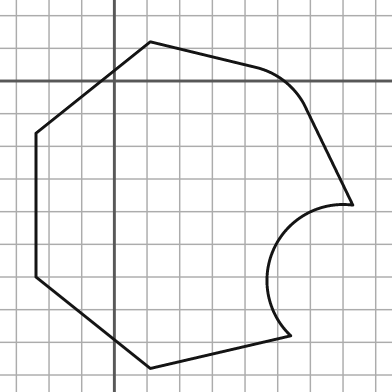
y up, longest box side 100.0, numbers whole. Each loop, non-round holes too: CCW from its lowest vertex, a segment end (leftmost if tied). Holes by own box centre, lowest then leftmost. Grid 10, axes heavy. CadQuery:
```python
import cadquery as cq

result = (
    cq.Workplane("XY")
    .moveTo(11.0, -88.0)
    .lineTo(54.0, -78.0)
    .threePointArc((49.0, -51.0), (73.0, -38.0))
    .lineTo(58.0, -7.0)
    .threePointArc((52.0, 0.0), (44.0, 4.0))
    .lineTo(11.0, 12.0)
    .lineTo(-24.0, -16.0)
    .lineTo(-24.0, -60.0)
    .close()
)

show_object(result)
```